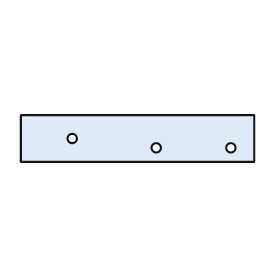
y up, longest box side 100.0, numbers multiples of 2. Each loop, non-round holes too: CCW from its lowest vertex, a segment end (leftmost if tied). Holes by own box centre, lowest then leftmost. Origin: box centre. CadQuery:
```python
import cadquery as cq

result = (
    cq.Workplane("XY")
    .moveTo(-50.0, -10.0)
    .lineTo(50.0, -10.0)
    .lineTo(50.0, 10.0)
    .lineTo(-50.0, 10.0)
    .close()
    .moveTo(8.0, -4.0)
    .circle(2.0)
    .moveTo(40.0, -4.0)
    .circle(2.0)
    .moveTo(-28.0, 0.0)
    .circle(2.0)
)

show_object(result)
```